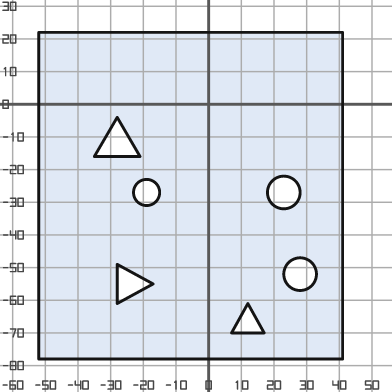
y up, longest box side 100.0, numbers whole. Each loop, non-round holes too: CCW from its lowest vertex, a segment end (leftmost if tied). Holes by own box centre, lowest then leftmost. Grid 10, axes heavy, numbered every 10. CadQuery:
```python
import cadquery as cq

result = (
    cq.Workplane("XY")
    .moveTo(-52.0, -78.0)
    .lineTo(41.0, -78.0)
    .lineTo(41.0, 22.0)
    .lineTo(-52.0, 22.0)
    .close()
    .moveTo(7.0, -70.0)
    .lineTo(17.0, -70.0)
    .lineTo(12.0, -61.0)
    .close()
    .moveTo(-28.0, -61.0)
    .lineTo(-17.0, -55.0)
    .lineTo(-28.0, -49.0)
    .close()
    .moveTo(28.0, -52.0)
    .circle(5.0)
    .moveTo(-19.0, -27.0)
    .circle(4.0)
    .moveTo(23.0, -27.0)
    .circle(5.0)
    .moveTo(-35.0, -16.0)
    .lineTo(-21.0, -16.0)
    .lineTo(-28.0, -4.0)
    .close()
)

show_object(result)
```